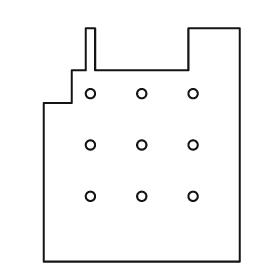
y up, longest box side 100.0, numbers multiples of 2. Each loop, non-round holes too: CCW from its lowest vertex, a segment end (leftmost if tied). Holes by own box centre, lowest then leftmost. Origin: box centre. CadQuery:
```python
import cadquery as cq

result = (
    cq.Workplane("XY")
    .moveTo(-42.0, -50.0)
    .lineTo(42.0, -50.0)
    .lineTo(42.0, 50.0)
    .lineTo(20.0, 50.0)
    .lineTo(20.0, 32.0)
    .lineTo(-20.0, 32.0)
    .lineTo(-20.0, 50.0)
    .lineTo(-24.0, 50.0)
    .lineTo(-24.0, 32.0)
    .lineTo(-30.0, 32.0)
    .lineTo(-30.0, 18.0)
    .lineTo(-42.0, 18.0)
    .close()
    .moveTo(-22.0, -22.0)
    .circle(2.0)
    .moveTo(0.0, -22.0)
    .circle(2.0)
    .moveTo(22.0, -22.0)
    .circle(2.0)
    .moveTo(-22.0, 0.0)
    .circle(2.0)
    .moveTo(0.0, 0.0)
    .circle(2.0)
    .moveTo(22.0, 0.0)
    .circle(2.0)
    .moveTo(-22.0, 22.0)
    .circle(2.0)
    .moveTo(0.0, 22.0)
    .circle(2.0)
    .moveTo(22.0, 22.0)
    .circle(2.0)
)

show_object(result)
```